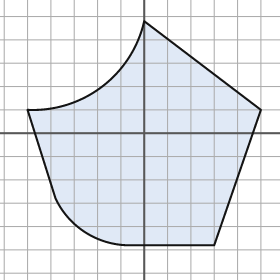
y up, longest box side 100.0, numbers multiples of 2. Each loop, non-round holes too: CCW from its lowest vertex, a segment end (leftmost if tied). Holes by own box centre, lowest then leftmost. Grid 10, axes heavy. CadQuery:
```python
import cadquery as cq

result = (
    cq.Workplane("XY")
    .moveTo(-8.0, -48.0)
    .lineTo(30.0, -48.0)
    .lineTo(50.0, 10.0)
    .lineTo(0.0, 48.0)
    .threePointArc((-18.0, 20.0), (-50.0, 10.0))
    .lineTo(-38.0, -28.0)
    .threePointArc((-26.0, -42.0), (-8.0, -48.0))
    .close()
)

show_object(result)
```